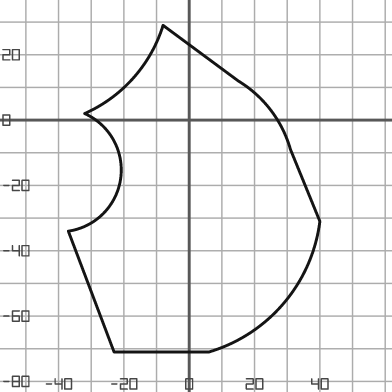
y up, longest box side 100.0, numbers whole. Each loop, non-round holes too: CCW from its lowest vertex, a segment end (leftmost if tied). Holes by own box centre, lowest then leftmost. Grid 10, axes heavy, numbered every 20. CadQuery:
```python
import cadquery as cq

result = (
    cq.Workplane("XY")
    .moveTo(-23.0, -71.0)
    .lineTo(6.0, -71.0)
    .threePointArc((29.0, -56.0), (40.0, -31.0))
    .lineTo(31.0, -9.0)
    .threePointArc((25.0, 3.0), (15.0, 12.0))
    .lineTo(-8.0, 29.0)
    .threePointArc((-17.0, 13.0), (-32.0, 2.0))
    .threePointArc((-21.0, -18.0), (-37.0, -34.0))
    .close()
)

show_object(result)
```